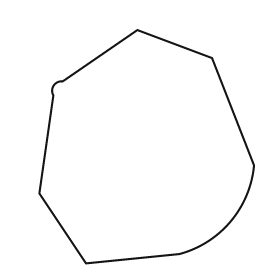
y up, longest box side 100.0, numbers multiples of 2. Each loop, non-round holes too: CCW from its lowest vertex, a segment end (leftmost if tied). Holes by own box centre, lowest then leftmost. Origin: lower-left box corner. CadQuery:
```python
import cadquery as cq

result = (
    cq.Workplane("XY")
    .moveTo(20.0, 0.0)
    .lineTo(60.0, 4.0)
    .threePointArc((82.0, 18.0), (92.0, 42.0))
    .lineTo(74.0, 88.0)
    .lineTo(42.0, 100.0)
    .lineTo(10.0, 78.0)
    .threePointArc((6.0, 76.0), (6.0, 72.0))
    .lineTo(0.0, 30.0)
    .close()
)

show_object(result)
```